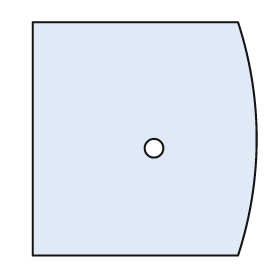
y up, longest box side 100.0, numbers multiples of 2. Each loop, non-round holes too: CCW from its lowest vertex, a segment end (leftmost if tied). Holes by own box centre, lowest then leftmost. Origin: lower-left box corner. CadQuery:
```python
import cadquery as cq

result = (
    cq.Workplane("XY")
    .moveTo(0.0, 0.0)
    .lineTo(88.0, 0.0)
    .threePointArc((96.0, 50.0), (88.0, 100.0))
    .lineTo(0.0, 100.0)
    .close()
    .moveTo(52.0, 46.0)
    .circle(4.0)
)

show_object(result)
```